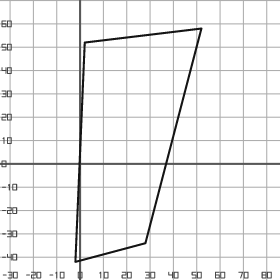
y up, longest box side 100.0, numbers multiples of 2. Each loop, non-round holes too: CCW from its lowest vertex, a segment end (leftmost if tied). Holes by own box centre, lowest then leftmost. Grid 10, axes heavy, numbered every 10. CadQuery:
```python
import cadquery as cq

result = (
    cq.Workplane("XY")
    .moveTo(-2.0, -42.0)
    .lineTo(28.0, -34.0)
    .lineTo(52.0, 58.0)
    .lineTo(2.0, 52.0)
    .close()
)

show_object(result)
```